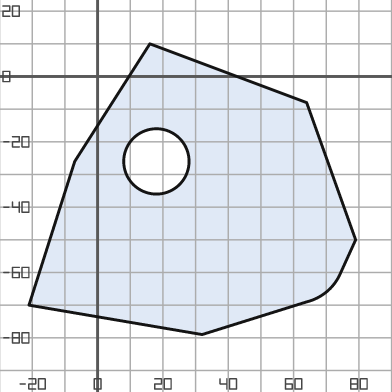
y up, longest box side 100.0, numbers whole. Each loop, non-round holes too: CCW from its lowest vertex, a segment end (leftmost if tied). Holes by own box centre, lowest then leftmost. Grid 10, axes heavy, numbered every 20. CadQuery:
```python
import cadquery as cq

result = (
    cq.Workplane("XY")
    .moveTo(32.0, -79.0)
    .lineTo(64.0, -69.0)
    .threePointArc((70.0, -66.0), (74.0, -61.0))
    .lineTo(79.0, -50.0)
    .lineTo(64.0, -8.0)
    .lineTo(16.0, 10.0)
    .lineTo(-7.0, -26.0)
    .lineTo(-21.0, -70.0)
    .close()
    .moveTo(18.0, -26.0)
    .circle(10.0)
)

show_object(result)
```